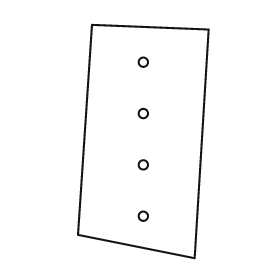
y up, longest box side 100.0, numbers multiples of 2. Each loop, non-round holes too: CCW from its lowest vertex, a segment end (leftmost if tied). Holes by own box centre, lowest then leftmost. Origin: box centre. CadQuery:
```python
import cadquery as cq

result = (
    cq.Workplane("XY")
    .moveTo(22.0, -50.0)
    .lineTo(28.0, 48.0)
    .lineTo(-22.0, 50.0)
    .lineTo(-28.0, -40.0)
    .close()
    .moveTo(0.0, -32.0)
    .circle(2.0)
    .moveTo(0.0, -10.0)
    .circle(2.0)
    .moveTo(0.0, 12.0)
    .circle(2.0)
    .moveTo(0.0, 34.0)
    .circle(2.0)
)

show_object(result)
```